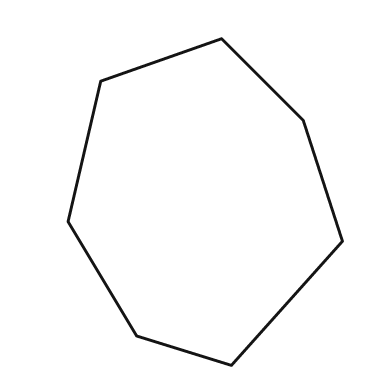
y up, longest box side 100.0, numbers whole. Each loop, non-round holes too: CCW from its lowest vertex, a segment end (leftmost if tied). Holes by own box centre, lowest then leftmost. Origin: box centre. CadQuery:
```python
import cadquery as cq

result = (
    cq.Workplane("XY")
    .moveTo(8.0, -50.0)
    .lineTo(42.0, -12.0)
    .lineTo(30.0, 25.0)
    .lineTo(5.0, 50.0)
    .lineTo(-32.0, 37.0)
    .lineTo(-42.0, -6.0)
    .lineTo(-21.0, -41.0)
    .close()
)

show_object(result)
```